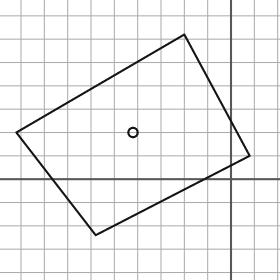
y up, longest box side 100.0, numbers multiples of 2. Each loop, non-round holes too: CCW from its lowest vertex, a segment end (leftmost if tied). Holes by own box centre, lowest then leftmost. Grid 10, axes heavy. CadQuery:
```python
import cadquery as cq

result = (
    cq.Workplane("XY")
    .moveTo(-58.0, -24.0)
    .lineTo(8.0, 10.0)
    .lineTo(-20.0, 62.0)
    .lineTo(-92.0, 20.0)
    .close()
    .moveTo(-42.0, 20.0)
    .circle(2.0)
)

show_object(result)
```